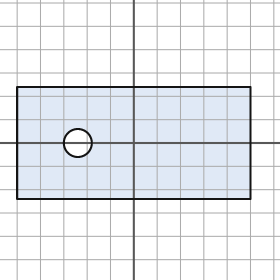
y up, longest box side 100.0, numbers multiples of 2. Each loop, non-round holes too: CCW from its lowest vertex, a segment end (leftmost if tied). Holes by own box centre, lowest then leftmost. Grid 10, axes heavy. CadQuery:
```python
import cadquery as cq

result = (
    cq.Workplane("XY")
    .moveTo(-50.0, -24.0)
    .lineTo(50.0, -24.0)
    .lineTo(50.0, 24.0)
    .lineTo(-50.0, 24.0)
    .close()
    .moveTo(-24.0, 0.0)
    .circle(6.0)
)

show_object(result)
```